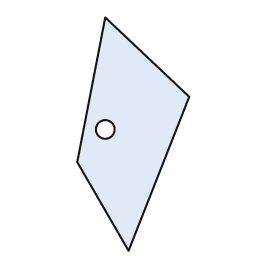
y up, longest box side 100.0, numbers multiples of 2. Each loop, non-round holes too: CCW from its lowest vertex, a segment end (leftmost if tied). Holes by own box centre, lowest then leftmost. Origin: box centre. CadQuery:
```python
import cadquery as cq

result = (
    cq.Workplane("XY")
    .moveTo(-2.0, -50.0)
    .lineTo(24.0, 16.0)
    .lineTo(-12.0, 50.0)
    .lineTo(-24.0, -12.0)
    .close()
    .moveTo(-12.0, 2.0)
    .circle(4.0)
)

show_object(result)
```